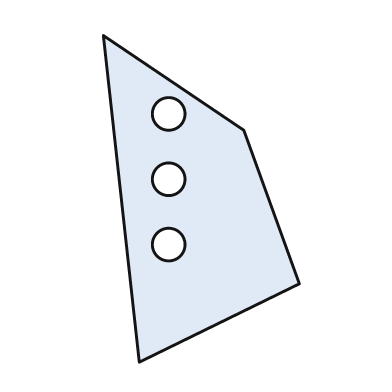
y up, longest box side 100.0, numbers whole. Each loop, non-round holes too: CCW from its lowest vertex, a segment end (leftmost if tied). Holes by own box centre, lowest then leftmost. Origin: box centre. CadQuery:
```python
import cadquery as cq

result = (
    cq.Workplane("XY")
    .moveTo(-19.0, -50.0)
    .lineTo(30.0, -26.0)
    .lineTo(13.0, 21.0)
    .lineTo(-30.0, 50.0)
    .close()
    .moveTo(-10.0, -14.0)
    .circle(5.0)
    .moveTo(-10.0, 6.0)
    .circle(5.0)
    .moveTo(-10.0, 26.0)
    .circle(5.0)
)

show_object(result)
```